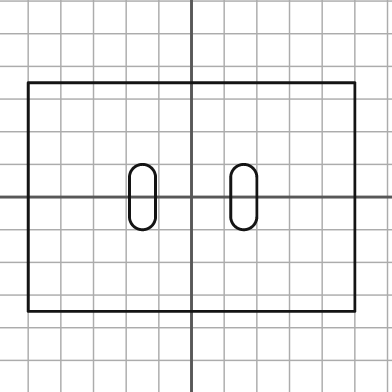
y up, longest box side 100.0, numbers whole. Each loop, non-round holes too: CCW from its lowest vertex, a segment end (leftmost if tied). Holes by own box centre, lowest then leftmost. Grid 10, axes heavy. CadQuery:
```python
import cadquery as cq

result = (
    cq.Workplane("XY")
    .moveTo(-50.0, -35.0)
    .lineTo(50.0, -35.0)
    .lineTo(50.0, 35.0)
    .lineTo(-50.0, 35.0)
    .close()
    .moveTo(-19.0, -6.0)
    .threePointArc((-15.0, -10.0), (-11.0, -6.0))
    .lineTo(-11.0, 6.0)
    .threePointArc((-15.0, 10.0), (-19.0, 6.0))
    .close()
    .moveTo(12.0, -6.0)
    .threePointArc((16.0, -10.0), (20.0, -6.0))
    .lineTo(20.0, 6.0)
    .threePointArc((16.0, 10.0), (12.0, 6.0))
    .close()
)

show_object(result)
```